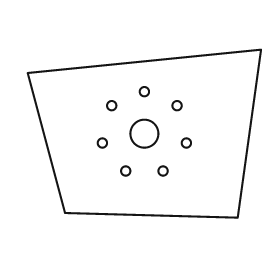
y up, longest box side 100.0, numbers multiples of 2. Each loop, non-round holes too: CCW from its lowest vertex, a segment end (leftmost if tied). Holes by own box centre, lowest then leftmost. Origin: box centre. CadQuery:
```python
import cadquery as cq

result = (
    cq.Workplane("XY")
    .moveTo(40.0, -36.0)
    .lineTo(50.0, 36.0)
    .lineTo(-50.0, 26.0)
    .lineTo(-34.0, -34.0)
    .close()
    .moveTo(-8.0, -16.0)
    .circle(2.0)
    .moveTo(8.0, -16.0)
    .circle(2.0)
    .moveTo(-18.0, -4.0)
    .circle(2.0)
    .moveTo(18.0, -4.0)
    .circle(2.0)
    .moveTo(0.0, 0.0)
    .circle(6.0)
    .moveTo(-14.0, 12.0)
    .circle(2.0)
    .moveTo(14.0, 12.0)
    .circle(2.0)
    .moveTo(0.0, 18.0)
    .circle(2.0)
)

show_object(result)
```